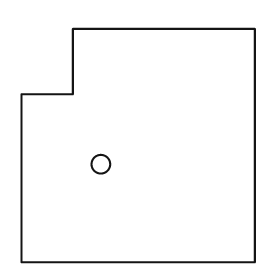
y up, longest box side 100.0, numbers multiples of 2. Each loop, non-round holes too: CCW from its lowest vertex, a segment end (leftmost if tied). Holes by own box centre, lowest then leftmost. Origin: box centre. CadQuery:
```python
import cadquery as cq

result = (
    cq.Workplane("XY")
    .moveTo(-50.0, -50.0)
    .lineTo(50.0, -50.0)
    .lineTo(50.0, 50.0)
    .lineTo(-28.0, 50.0)
    .lineTo(-28.0, 22.0)
    .lineTo(-50.0, 22.0)
    .close()
    .moveTo(-16.0, -8.0)
    .circle(4.0)
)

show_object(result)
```